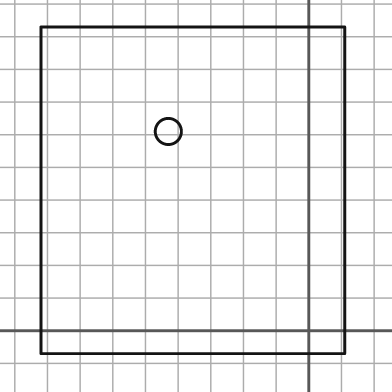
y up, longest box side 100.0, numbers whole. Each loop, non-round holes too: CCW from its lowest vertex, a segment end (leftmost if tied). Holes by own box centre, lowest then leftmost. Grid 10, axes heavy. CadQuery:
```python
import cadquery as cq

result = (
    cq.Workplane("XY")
    .moveTo(-82.0, -7.0)
    .lineTo(11.0, -7.0)
    .lineTo(11.0, 93.0)
    .lineTo(-82.0, 93.0)
    .close()
    .moveTo(-43.0, 61.0)
    .circle(4.0)
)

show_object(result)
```